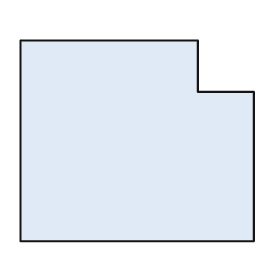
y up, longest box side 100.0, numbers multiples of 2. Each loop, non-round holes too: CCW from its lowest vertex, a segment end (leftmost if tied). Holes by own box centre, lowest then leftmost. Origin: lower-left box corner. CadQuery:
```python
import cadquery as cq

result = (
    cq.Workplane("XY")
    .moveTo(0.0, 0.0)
    .lineTo(100.0, 0.0)
    .lineTo(100.0, 64.0)
    .lineTo(76.0, 64.0)
    .lineTo(76.0, 86.0)
    .lineTo(0.0, 86.0)
    .close()
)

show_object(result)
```